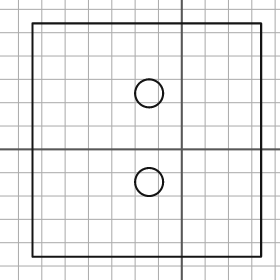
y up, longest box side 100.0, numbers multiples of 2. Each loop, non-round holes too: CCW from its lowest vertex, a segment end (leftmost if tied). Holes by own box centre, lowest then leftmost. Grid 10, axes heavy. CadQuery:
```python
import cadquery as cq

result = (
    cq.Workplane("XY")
    .moveTo(-64.0, -46.0)
    .lineTo(34.0, -46.0)
    .lineTo(34.0, 54.0)
    .lineTo(-64.0, 54.0)
    .close()
    .moveTo(-14.0, -14.0)
    .circle(6.0)
    .moveTo(-14.0, 24.0)
    .circle(6.0)
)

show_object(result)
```